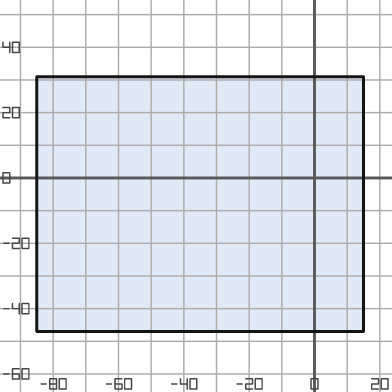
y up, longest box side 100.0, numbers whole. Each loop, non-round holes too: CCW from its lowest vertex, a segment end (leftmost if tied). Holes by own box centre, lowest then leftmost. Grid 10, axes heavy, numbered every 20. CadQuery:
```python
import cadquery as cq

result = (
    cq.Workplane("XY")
    .moveTo(-85.0, -47.0)
    .lineTo(15.0, -47.0)
    .lineTo(15.0, 31.0)
    .lineTo(-85.0, 31.0)
    .close()
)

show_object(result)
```